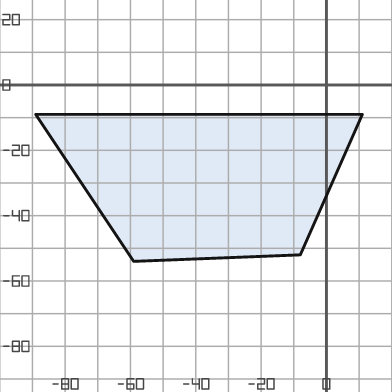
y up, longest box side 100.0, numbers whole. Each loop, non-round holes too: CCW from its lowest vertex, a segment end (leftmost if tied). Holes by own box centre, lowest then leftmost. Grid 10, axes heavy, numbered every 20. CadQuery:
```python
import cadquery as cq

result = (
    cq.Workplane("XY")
    .moveTo(-59.0, -54.0)
    .lineTo(-8.0, -52.0)
    .lineTo(11.0, -9.0)
    .lineTo(-89.0, -9.0)
    .close()
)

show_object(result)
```